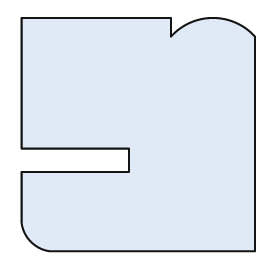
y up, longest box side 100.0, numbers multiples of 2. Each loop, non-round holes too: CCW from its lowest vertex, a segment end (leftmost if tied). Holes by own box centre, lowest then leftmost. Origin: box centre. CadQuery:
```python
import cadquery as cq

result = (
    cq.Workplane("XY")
    .moveTo(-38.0, -50.0)
    .lineTo(50.0, -50.0)
    .lineTo(50.0, 42.0)
    .threePointArc((32.0, 50.0), (14.0, 42.0))
    .lineTo(14.0, 50.0)
    .lineTo(-50.0, 50.0)
    .lineTo(-50.0, -6.0)
    .lineTo(-4.0, -6.0)
    .lineTo(-4.0, -16.0)
    .lineTo(-50.0, -16.0)
    .lineTo(-50.0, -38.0)
    .threePointArc((-46.0, -46.0), (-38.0, -50.0))
    .close()
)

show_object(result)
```